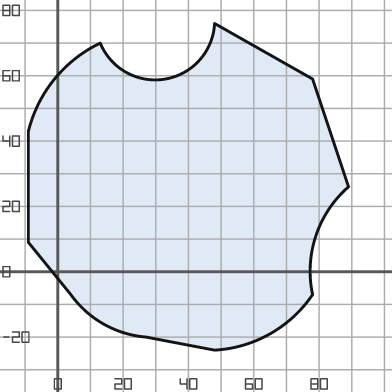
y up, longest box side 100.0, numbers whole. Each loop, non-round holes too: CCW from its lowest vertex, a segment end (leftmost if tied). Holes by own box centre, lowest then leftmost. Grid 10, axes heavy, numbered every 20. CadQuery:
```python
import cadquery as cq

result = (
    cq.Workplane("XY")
    .moveTo(48.0, -24.0)
    .threePointArc((65.0, -19.0), (78.0, -7.0))
    .threePointArc((79.0, 11.0), (89.0, 26.0))
    .lineTo(78.0, 59.0)
    .lineTo(48.0, 76.0)
    .threePointArc((33.0, 59.0), (13.0, 70.0))
    .threePointArc((-1.0, 59.0), (-9.0, 43.0))
    .lineTo(-9.0, 9.0)
    .lineTo(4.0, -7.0)
    .threePointArc((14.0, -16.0), (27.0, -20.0))
    .close()
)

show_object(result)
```